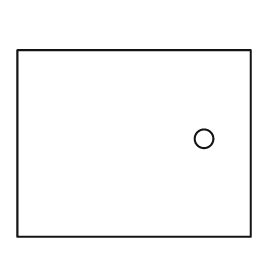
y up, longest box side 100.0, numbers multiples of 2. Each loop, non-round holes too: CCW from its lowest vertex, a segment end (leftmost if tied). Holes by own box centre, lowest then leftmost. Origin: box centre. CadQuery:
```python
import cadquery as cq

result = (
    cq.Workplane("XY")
    .moveTo(-50.0, -40.0)
    .lineTo(50.0, -40.0)
    .lineTo(50.0, 40.0)
    .lineTo(-50.0, 40.0)
    .close()
    .moveTo(30.0, 2.0)
    .circle(4.0)
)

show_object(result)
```